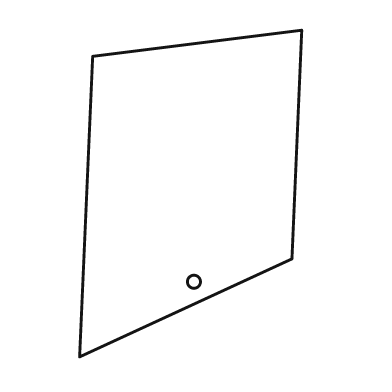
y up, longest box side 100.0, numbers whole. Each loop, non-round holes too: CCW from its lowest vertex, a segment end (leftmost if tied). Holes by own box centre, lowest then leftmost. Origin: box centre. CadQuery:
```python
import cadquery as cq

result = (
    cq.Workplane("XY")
    .moveTo(-34.0, -50.0)
    .lineTo(31.0, -20.0)
    .lineTo(34.0, 50.0)
    .lineTo(-30.0, 42.0)
    .close()
    .moveTo(1.0, -27.0)
    .circle(2.0)
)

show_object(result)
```